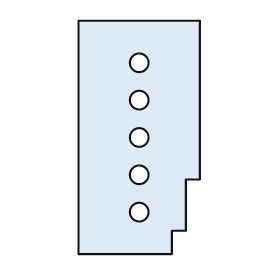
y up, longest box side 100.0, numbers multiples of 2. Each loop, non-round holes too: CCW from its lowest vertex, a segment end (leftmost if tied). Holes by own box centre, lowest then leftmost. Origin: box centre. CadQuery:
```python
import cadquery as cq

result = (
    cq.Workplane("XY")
    .moveTo(-26.0, -50.0)
    .lineTo(14.0, -50.0)
    .lineTo(14.0, -40.0)
    .lineTo(20.0, -40.0)
    .lineTo(20.0, -18.0)
    .lineTo(26.0, -18.0)
    .lineTo(26.0, 50.0)
    .lineTo(-26.0, 50.0)
    .close()
    .moveTo(0.0, -32.0)
    .circle(4.0)
    .moveTo(0.0, -16.0)
    .circle(4.0)
    .moveTo(0.0, 0.0)
    .circle(4.0)
    .moveTo(0.0, 16.0)
    .circle(4.0)
    .moveTo(0.0, 32.0)
    .circle(4.0)
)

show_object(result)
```